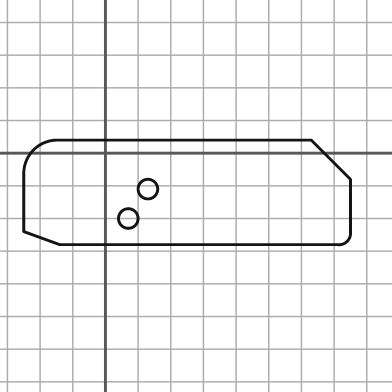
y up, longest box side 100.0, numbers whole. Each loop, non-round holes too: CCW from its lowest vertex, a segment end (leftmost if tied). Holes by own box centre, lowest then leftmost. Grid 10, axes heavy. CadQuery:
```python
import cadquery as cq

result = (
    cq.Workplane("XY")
    .moveTo(-14.0, -28.0)
    .lineTo(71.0, -28.0)
    .threePointArc((74.0, -27.0), (75.0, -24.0))
    .lineTo(75.0, -8.0)
    .lineTo(63.0, 4.0)
    .lineTo(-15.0, 4.0)
    .threePointArc((-22.0, 1.0), (-25.0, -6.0))
    .lineTo(-25.0, -24.0)
    .close()
    .moveTo(7.0, -20.0)
    .circle(3.0)
    .moveTo(13.0, -11.0)
    .circle(3.0)
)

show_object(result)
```